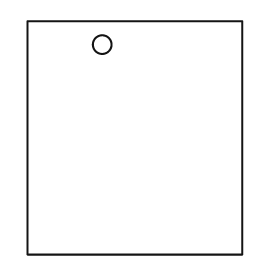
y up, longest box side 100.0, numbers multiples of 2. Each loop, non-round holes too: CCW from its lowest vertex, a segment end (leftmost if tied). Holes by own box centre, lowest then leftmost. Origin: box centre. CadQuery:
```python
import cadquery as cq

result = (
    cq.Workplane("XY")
    .moveTo(-46.0, -50.0)
    .lineTo(46.0, -50.0)
    .lineTo(46.0, 50.0)
    .lineTo(-46.0, 50.0)
    .close()
    .moveTo(-14.0, 40.0)
    .circle(4.0)
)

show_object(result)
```